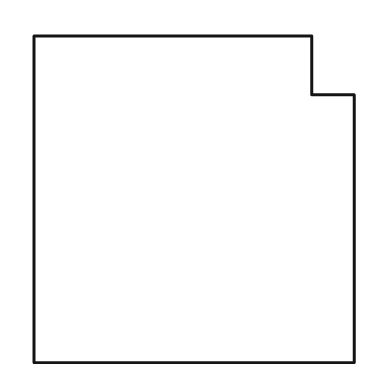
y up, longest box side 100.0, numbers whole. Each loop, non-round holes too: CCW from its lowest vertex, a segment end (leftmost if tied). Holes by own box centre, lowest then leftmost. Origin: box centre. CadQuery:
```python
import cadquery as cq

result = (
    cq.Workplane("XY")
    .moveTo(-49.0, -50.0)
    .lineTo(49.0, -50.0)
    .lineTo(49.0, 32.0)
    .lineTo(36.0, 32.0)
    .lineTo(36.0, 50.0)
    .lineTo(-49.0, 50.0)
    .close()
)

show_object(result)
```